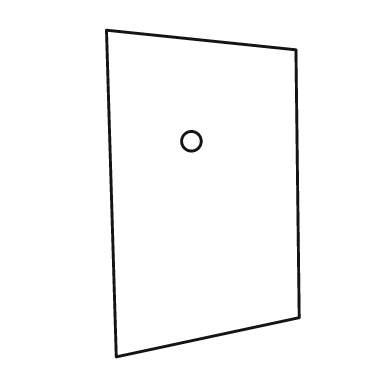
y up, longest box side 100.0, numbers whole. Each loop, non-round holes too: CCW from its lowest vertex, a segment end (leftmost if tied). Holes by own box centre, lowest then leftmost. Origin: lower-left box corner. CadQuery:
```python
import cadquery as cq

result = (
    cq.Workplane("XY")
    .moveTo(3.0, 0.0)
    .lineTo(59.0, 12.0)
    .lineTo(58.0, 94.0)
    .lineTo(0.0, 100.0)
    .close()
    .moveTo(26.0, 66.0)
    .circle(3.0)
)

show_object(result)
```